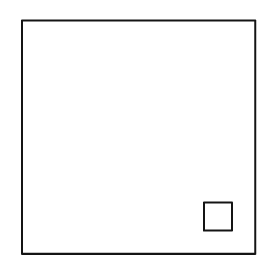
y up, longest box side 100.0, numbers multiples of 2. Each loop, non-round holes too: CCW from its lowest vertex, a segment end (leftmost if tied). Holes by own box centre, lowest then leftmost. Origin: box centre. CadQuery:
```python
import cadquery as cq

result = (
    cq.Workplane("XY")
    .moveTo(-50.0, -50.0)
    .lineTo(50.0, -50.0)
    .lineTo(50.0, 50.0)
    .lineTo(-50.0, 50.0)
    .close()
    .moveTo(28.0, -40.0)
    .lineTo(40.0, -40.0)
    .lineTo(40.0, -28.0)
    .lineTo(28.0, -28.0)
    .close()
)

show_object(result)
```